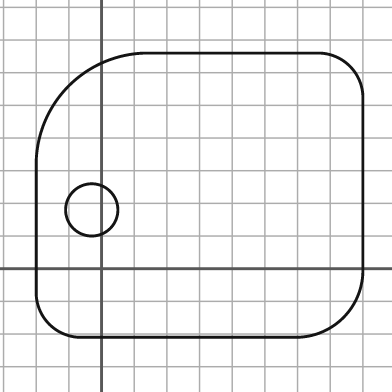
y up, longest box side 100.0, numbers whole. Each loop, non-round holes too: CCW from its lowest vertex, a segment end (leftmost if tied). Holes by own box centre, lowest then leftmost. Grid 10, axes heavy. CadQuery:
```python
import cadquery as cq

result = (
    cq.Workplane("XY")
    .moveTo(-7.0, -21.0)
    .lineTo(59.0, -21.0)
    .threePointArc((74.0, -15.0), (80.0, 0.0))
    .lineTo(80.0, 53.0)
    .threePointArc((76.0, 62.0), (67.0, 66.0))
    .lineTo(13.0, 66.0)
    .threePointArc((-10.0, 56.0), (-20.0, 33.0))
    .lineTo(-20.0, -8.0)
    .threePointArc((-16.0, -17.0), (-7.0, -21.0))
    .close()
    .moveTo(-3.0, 18.0)
    .circle(8.0)
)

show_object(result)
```